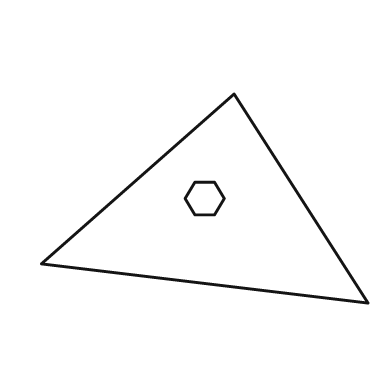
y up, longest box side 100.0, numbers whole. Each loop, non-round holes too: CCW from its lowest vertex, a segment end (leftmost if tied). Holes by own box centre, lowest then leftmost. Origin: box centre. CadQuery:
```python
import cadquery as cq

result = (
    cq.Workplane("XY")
    .moveTo(50.0, -32.0)
    .lineTo(9.0, 32.0)
    .lineTo(-50.0, -20.0)
    .close()
    .moveTo(-3.0, -5.0)
    .lineTo(3.0, -5.0)
    .lineTo(6.0, 0.0)
    .lineTo(3.0, 5.0)
    .lineTo(-3.0, 5.0)
    .lineTo(-6.0, 0.0)
    .close()
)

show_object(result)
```